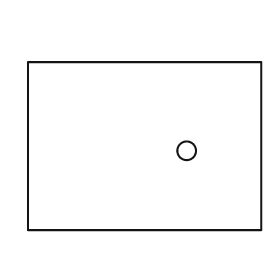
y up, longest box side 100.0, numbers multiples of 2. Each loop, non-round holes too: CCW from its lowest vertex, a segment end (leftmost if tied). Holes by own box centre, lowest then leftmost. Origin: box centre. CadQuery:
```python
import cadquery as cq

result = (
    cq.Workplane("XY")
    .moveTo(-50.0, -36.0)
    .lineTo(50.0, -36.0)
    .lineTo(50.0, 36.0)
    .lineTo(-50.0, 36.0)
    .close()
    .moveTo(18.0, -2.0)
    .circle(4.0)
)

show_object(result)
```